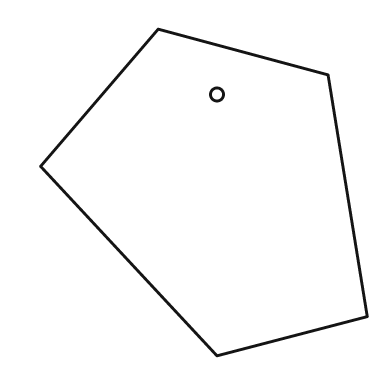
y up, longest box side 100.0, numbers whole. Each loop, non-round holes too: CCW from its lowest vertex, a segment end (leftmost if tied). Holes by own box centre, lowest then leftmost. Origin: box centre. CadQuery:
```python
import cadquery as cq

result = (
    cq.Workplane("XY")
    .moveTo(4.0, -50.0)
    .lineTo(50.0, -38.0)
    .lineTo(38.0, 36.0)
    .lineTo(-14.0, 50.0)
    .lineTo(-50.0, 8.0)
    .close()
    .moveTo(4.0, 30.0)
    .circle(2.0)
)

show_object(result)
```